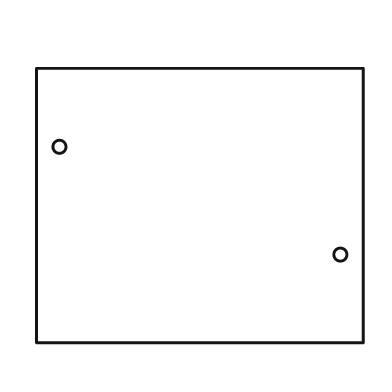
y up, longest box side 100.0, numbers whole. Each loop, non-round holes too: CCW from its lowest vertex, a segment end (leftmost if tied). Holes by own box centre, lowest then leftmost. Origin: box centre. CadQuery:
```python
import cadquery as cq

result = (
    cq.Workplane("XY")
    .moveTo(-50.0, -42.0)
    .lineTo(50.0, -42.0)
    .lineTo(50.0, 42.0)
    .lineTo(-50.0, 42.0)
    .close()
    .moveTo(43.0, -15.0)
    .circle(2.0)
    .moveTo(-43.0, 18.0)
    .circle(2.0)
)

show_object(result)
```